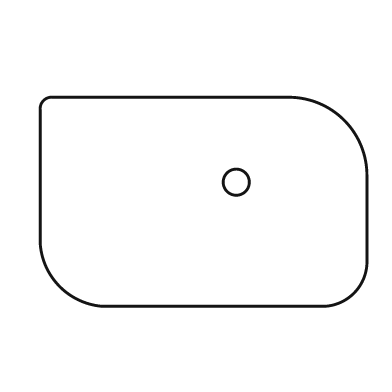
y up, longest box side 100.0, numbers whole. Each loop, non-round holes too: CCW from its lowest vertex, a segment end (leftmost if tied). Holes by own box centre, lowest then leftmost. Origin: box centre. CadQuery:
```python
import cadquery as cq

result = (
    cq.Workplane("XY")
    .moveTo(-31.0, -32.0)
    .lineTo(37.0, -32.0)
    .threePointArc((46.0, -28.0), (50.0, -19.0))
    .lineTo(50.0, 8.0)
    .threePointArc((43.0, 25.0), (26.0, 32.0))
    .lineTo(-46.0, 32.0)
    .threePointArc((-49.0, 31.0), (-50.0, 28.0))
    .lineTo(-50.0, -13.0)
    .threePointArc((-44.0, -26.0), (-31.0, -32.0))
    .close()
    .moveTo(10.0, 6.0)
    .circle(4.0)
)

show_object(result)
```